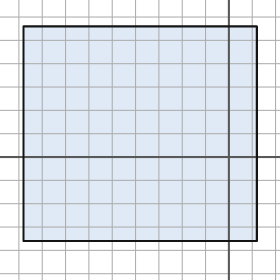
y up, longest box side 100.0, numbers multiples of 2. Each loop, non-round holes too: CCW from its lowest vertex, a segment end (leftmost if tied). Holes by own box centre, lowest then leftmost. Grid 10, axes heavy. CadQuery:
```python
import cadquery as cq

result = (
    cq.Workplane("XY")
    .moveTo(-88.0, -36.0)
    .lineTo(12.0, -36.0)
    .lineTo(12.0, 56.0)
    .lineTo(-88.0, 56.0)
    .close()
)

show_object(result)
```